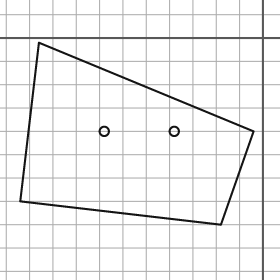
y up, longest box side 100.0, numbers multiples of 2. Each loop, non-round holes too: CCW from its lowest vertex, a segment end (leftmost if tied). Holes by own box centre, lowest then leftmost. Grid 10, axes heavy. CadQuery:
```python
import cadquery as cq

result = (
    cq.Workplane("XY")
    .moveTo(-18.0, -80.0)
    .lineTo(-4.0, -40.0)
    .lineTo(-96.0, -2.0)
    .lineTo(-104.0, -70.0)
    .close()
    .moveTo(-68.0, -40.0)
    .circle(2.0)
    .moveTo(-38.0, -40.0)
    .circle(2.0)
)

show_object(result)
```